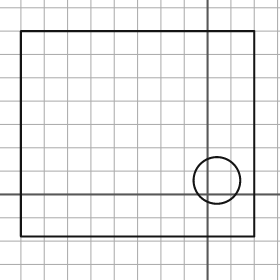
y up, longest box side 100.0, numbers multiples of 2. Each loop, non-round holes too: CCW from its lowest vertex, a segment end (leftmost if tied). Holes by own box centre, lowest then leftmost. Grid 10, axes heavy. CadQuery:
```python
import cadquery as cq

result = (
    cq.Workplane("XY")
    .moveTo(-80.0, -18.0)
    .lineTo(20.0, -18.0)
    .lineTo(20.0, 70.0)
    .lineTo(-80.0, 70.0)
    .close()
    .moveTo(4.0, 6.0)
    .circle(10.0)
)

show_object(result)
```